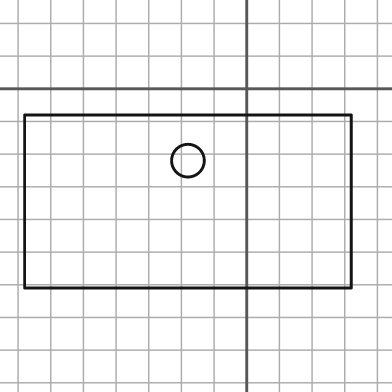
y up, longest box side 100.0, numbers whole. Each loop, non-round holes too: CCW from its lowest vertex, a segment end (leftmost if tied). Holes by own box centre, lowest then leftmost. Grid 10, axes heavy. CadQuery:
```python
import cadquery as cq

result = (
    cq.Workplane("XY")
    .moveTo(-68.0, -61.0)
    .lineTo(32.0, -61.0)
    .lineTo(32.0, -8.0)
    .lineTo(-68.0, -8.0)
    .close()
    .moveTo(-18.0, -22.0)
    .circle(5.0)
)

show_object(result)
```